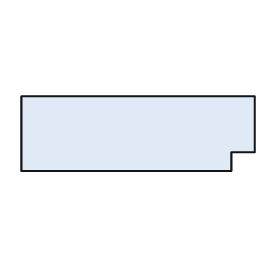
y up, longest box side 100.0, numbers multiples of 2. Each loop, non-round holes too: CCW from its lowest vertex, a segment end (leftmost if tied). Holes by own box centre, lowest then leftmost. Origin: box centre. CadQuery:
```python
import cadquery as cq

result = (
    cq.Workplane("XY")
    .moveTo(-50.0, -16.0)
    .lineTo(40.0, -16.0)
    .lineTo(40.0, -8.0)
    .lineTo(50.0, -8.0)
    .lineTo(50.0, 16.0)
    .lineTo(-50.0, 16.0)
    .close()
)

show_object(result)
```